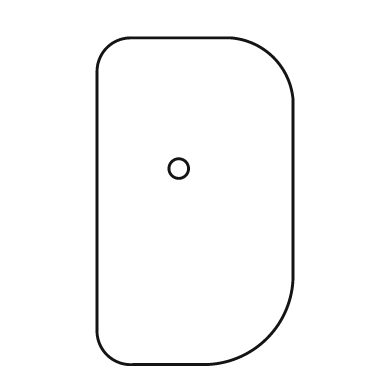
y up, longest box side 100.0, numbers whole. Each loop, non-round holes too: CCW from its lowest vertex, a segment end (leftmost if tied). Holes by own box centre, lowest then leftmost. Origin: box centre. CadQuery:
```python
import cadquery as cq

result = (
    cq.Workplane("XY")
    .moveTo(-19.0, -50.0)
    .lineTo(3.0, -50.0)
    .threePointArc((22.0, -42.0), (30.0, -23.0))
    .lineTo(30.0, 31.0)
    .threePointArc((24.0, 44.0), (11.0, 50.0))
    .lineTo(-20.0, 50.0)
    .threePointArc((-27.0, 47.0), (-30.0, 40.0))
    .lineTo(-30.0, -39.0)
    .threePointArc((-27.0, -47.0), (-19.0, -50.0))
    .close()
    .moveTo(-5.0, 10.0)
    .circle(3.0)
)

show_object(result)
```